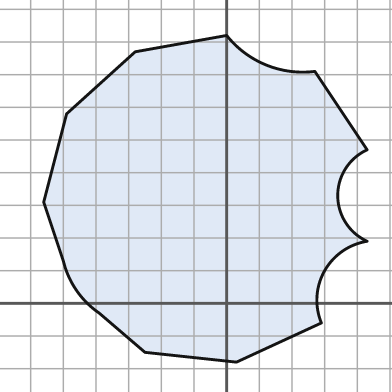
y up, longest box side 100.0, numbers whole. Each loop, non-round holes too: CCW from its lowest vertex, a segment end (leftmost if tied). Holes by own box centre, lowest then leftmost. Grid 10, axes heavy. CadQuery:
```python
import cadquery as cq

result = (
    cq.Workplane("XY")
    .moveTo(3.0, -18.0)
    .lineTo(29.0, -6.0)
    .threePointArc((30.0, 10.0), (43.0, 19.0))
    .threePointArc((34.0, 33.0), (43.0, 47.0))
    .lineTo(27.0, 71.0)
    .threePointArc((12.0, 73.0), (0.0, 82.0))
    .lineTo(-28.0, 77.0)
    .lineTo(-49.0, 58.0)
    .lineTo(-56.0, 31.0)
    .lineTo(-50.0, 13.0)
    .threePointArc((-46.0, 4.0), (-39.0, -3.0))
    .lineTo(-25.0, -15.0)
    .close()
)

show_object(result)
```